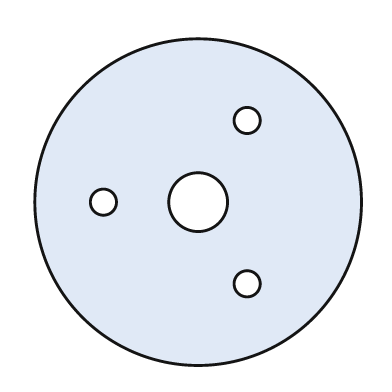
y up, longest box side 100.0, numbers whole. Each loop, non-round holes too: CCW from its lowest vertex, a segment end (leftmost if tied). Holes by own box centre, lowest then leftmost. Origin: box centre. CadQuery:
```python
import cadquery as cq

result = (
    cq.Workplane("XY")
    .moveTo(0.0, 0.0)
    .circle(50.0)
    .moveTo(15.0, -25.0)
    .circle(4.0)
    .moveTo(-29.0, 0.0)
    .circle(4.0)
    .moveTo(0.0, 0.0)
    .circle(9.0)
    .moveTo(15.0, 25.0)
    .circle(4.0)
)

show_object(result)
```